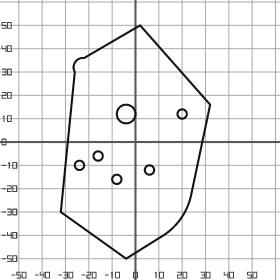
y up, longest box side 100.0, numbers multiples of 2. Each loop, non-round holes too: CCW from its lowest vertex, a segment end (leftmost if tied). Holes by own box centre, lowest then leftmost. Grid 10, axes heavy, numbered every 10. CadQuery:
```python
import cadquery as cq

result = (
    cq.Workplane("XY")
    .moveTo(-4.0, -50.0)
    .lineTo(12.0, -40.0)
    .threePointArc((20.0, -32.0), (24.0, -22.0))
    .lineTo(32.0, 16.0)
    .lineTo(2.0, 50.0)
    .lineTo(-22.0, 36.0)
    .threePointArc((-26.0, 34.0), (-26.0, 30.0))
    .lineTo(-32.0, -30.0)
    .close()
    .moveTo(-8.0, -16.0)
    .circle(2.0)
    .moveTo(6.0, -12.0)
    .circle(2.0)
    .moveTo(-24.0, -10.0)
    .circle(2.0)
    .moveTo(-16.0, -6.0)
    .circle(2.0)
    .moveTo(-4.0, 12.0)
    .circle(4.0)
    .moveTo(20.0, 12.0)
    .circle(2.0)
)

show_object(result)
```